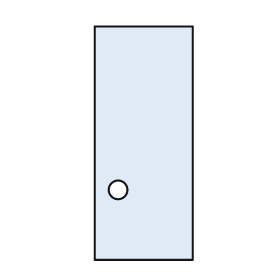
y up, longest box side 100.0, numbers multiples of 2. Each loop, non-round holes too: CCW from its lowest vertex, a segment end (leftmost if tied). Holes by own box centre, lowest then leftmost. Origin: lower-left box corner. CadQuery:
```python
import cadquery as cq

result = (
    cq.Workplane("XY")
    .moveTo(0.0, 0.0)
    .lineTo(42.0, 0.0)
    .lineTo(42.0, 100.0)
    .lineTo(0.0, 100.0)
    .close()
    .moveTo(10.0, 30.0)
    .circle(4.0)
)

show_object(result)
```